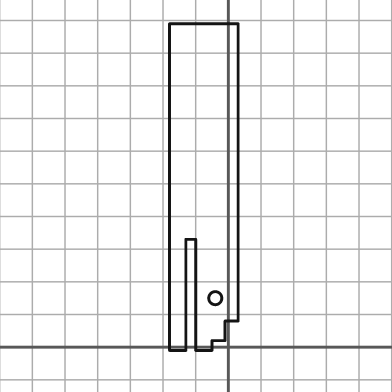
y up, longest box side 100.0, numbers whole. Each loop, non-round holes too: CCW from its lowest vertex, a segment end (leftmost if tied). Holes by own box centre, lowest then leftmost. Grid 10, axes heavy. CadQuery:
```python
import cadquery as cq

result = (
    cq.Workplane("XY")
    .moveTo(-18.0, -1.0)
    .lineTo(-13.0, -1.0)
    .lineTo(-13.0, 33.0)
    .lineTo(-10.0, 33.0)
    .lineTo(-10.0, -1.0)
    .lineTo(-5.0, -1.0)
    .lineTo(-5.0, 2.0)
    .lineTo(-1.0, 2.0)
    .lineTo(-1.0, 8.0)
    .lineTo(3.0, 8.0)
    .lineTo(3.0, 99.0)
    .lineTo(-18.0, 99.0)
    .close()
    .moveTo(-4.0, 15.0)
    .circle(2.0)
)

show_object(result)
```